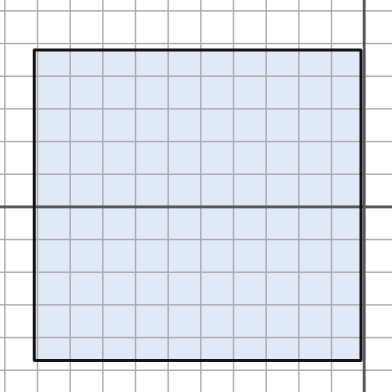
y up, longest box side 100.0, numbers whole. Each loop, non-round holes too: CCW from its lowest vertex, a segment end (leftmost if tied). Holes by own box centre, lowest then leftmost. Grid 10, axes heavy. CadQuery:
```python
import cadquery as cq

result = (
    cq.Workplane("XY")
    .moveTo(-101.0, -47.0)
    .lineTo(-1.0, -47.0)
    .lineTo(-1.0, 48.0)
    .lineTo(-101.0, 48.0)
    .close()
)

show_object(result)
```